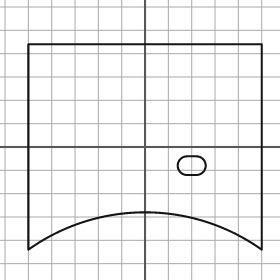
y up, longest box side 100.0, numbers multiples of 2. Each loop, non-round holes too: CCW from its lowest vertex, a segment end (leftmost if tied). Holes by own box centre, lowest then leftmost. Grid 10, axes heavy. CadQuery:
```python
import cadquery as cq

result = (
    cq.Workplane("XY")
    .moveTo(-50.0, -44.0)
    .threePointArc((0.0, -28.0), (50.0, -44.0))
    .lineTo(50.0, 44.0)
    .lineTo(-50.0, 44.0)
    .close()
    .moveTo(18.0, -12.0)
    .lineTo(22.0, -12.0)
    .threePointArc((26.0, -8.0), (22.0, -4.0))
    .lineTo(18.0, -4.0)
    .threePointArc((14.0, -8.0), (18.0, -12.0))
    .close()
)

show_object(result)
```